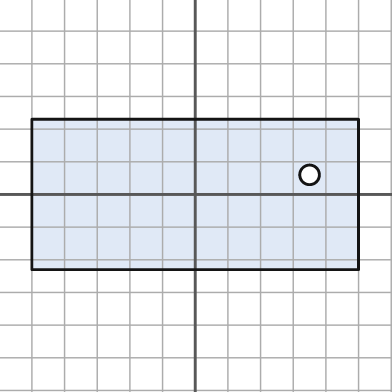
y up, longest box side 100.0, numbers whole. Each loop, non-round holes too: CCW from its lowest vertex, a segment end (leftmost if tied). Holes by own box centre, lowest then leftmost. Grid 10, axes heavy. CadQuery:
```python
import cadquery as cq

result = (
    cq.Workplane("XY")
    .moveTo(-50.0, -23.0)
    .lineTo(50.0, -23.0)
    .lineTo(50.0, 23.0)
    .lineTo(-50.0, 23.0)
    .close()
    .moveTo(35.0, 6.0)
    .circle(3.0)
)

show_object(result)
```